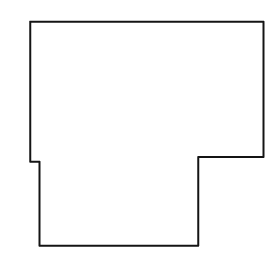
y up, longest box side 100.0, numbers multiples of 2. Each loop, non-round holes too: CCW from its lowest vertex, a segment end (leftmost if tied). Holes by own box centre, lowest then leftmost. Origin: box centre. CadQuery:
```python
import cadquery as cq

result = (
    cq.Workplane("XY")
    .moveTo(-46.0, -48.0)
    .lineTo(22.0, -48.0)
    .lineTo(22.0, -10.0)
    .lineTo(50.0, -10.0)
    .lineTo(50.0, 48.0)
    .lineTo(-50.0, 48.0)
    .lineTo(-50.0, -12.0)
    .lineTo(-46.0, -12.0)
    .close()
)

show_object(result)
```